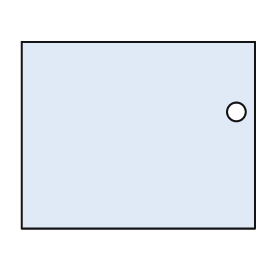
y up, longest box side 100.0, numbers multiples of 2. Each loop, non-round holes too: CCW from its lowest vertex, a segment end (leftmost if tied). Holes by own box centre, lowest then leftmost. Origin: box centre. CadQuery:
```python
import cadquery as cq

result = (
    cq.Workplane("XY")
    .moveTo(-50.0, -40.0)
    .lineTo(50.0, -40.0)
    .lineTo(50.0, 40.0)
    .lineTo(-50.0, 40.0)
    .close()
    .moveTo(42.0, 10.0)
    .circle(4.0)
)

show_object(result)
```